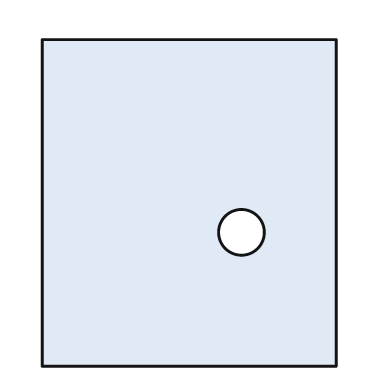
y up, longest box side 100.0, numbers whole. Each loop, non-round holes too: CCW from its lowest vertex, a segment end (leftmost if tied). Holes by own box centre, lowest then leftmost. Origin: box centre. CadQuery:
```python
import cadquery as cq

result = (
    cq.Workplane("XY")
    .moveTo(-45.0, -50.0)
    .lineTo(45.0, -50.0)
    .lineTo(45.0, 50.0)
    .lineTo(-45.0, 50.0)
    .close()
    .moveTo(16.0, -9.0)
    .circle(7.0)
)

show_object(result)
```